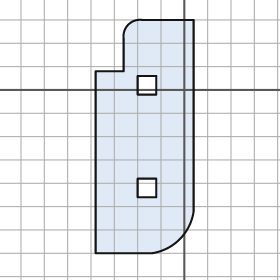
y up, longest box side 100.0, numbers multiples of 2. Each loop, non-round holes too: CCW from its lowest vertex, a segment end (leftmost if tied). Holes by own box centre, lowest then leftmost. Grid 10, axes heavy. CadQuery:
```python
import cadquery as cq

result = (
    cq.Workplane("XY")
    .moveTo(-38.0, -70.0)
    .lineTo(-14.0, -70.0)
    .threePointArc((-2.0, -64.0), (4.0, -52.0))
    .lineTo(4.0, 30.0)
    .lineTo(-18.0, 30.0)
    .threePointArc((-24.0, 28.0), (-26.0, 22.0))
    .lineTo(-26.0, 8.0)
    .lineTo(-38.0, 8.0)
    .close()
    .moveTo(-20.0, -46.0)
    .lineTo(-12.0, -46.0)
    .lineTo(-12.0, -38.0)
    .lineTo(-20.0, -38.0)
    .close()
    .moveTo(-20.0, -2.0)
    .lineTo(-12.0, -2.0)
    .lineTo(-12.0, 6.0)
    .lineTo(-20.0, 6.0)
    .close()
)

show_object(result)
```